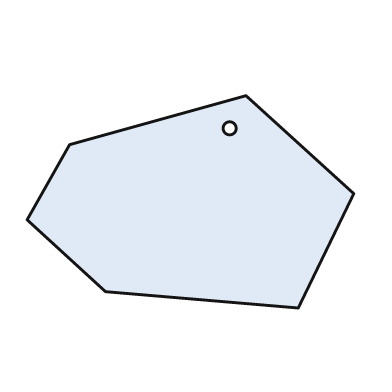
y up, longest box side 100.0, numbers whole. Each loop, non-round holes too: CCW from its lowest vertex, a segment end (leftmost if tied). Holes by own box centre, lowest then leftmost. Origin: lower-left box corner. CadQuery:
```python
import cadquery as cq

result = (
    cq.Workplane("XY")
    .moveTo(83.0, 0.0)
    .lineTo(100.0, 35.0)
    .lineTo(67.0, 65.0)
    .lineTo(13.0, 50.0)
    .lineTo(0.0, 27.0)
    .lineTo(24.0, 5.0)
    .close()
    .moveTo(62.0, 55.0)
    .circle(2.0)
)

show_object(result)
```